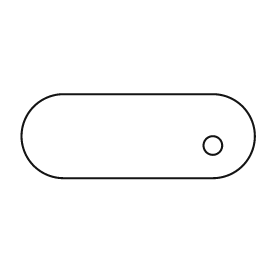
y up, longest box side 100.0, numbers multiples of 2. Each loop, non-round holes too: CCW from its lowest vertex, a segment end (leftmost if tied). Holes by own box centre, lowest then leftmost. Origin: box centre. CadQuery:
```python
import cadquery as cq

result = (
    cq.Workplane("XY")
    .moveTo(-32.0, -18.0)
    .lineTo(32.0, -18.0)
    .threePointArc((50.0, 0.0), (32.0, 18.0))
    .lineTo(-32.0, 18.0)
    .threePointArc((-50.0, 0.0), (-32.0, -18.0))
    .close()
    .moveTo(32.0, -4.0)
    .circle(4.0)
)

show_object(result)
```